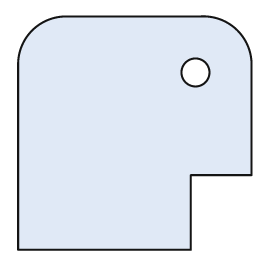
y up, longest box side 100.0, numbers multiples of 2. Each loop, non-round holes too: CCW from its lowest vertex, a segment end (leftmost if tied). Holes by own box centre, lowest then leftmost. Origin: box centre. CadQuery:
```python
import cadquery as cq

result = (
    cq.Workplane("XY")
    .moveTo(-50.0, -50.0)
    .lineTo(24.0, -50.0)
    .lineTo(24.0, -18.0)
    .lineTo(50.0, -18.0)
    .lineTo(50.0, 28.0)
    .threePointArc((44.0, 44.0), (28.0, 50.0))
    .lineTo(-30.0, 50.0)
    .threePointArc((-44.0, 44.0), (-50.0, 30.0))
    .close()
    .moveTo(26.0, 26.0)
    .circle(6.0)
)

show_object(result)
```